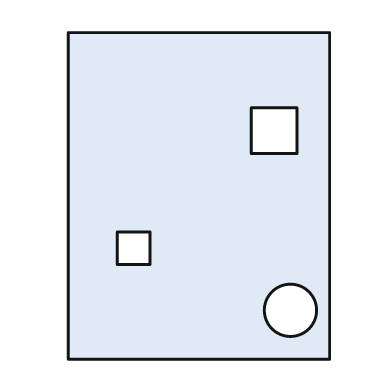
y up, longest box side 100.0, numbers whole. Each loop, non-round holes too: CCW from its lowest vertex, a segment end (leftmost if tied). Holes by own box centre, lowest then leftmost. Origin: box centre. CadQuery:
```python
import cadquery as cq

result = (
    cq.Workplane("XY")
    .moveTo(-40.0, -50.0)
    .lineTo(40.0, -50.0)
    .lineTo(40.0, 50.0)
    .lineTo(-40.0, 50.0)
    .close()
    .moveTo(28.0, -35.0)
    .circle(8.0)
    .moveTo(-25.0, -21.0)
    .lineTo(-15.0, -21.0)
    .lineTo(-15.0, -11.0)
    .lineTo(-25.0, -11.0)
    .close()
    .moveTo(16.0, 13.0)
    .lineTo(30.0, 13.0)
    .lineTo(30.0, 27.0)
    .lineTo(16.0, 27.0)
    .close()
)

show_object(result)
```